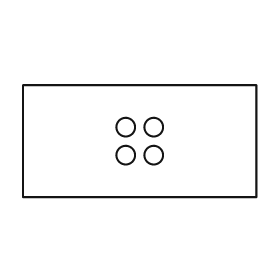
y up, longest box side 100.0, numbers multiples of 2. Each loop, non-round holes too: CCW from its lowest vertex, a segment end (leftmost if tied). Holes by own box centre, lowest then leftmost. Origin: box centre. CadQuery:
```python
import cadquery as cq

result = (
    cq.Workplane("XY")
    .moveTo(-50.0, -24.0)
    .lineTo(50.0, -24.0)
    .lineTo(50.0, 24.0)
    .lineTo(-50.0, 24.0)
    .close()
    .moveTo(-6.0, -6.0)
    .circle(4.0)
    .moveTo(6.0, -6.0)
    .circle(4.0)
    .moveTo(-6.0, 6.0)
    .circle(4.0)
    .moveTo(6.0, 6.0)
    .circle(4.0)
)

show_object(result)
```